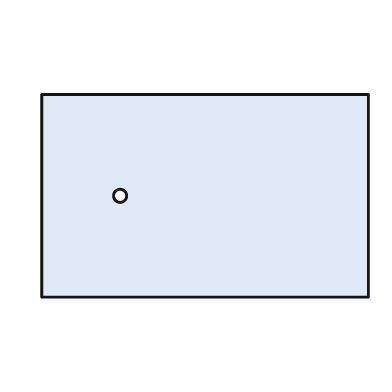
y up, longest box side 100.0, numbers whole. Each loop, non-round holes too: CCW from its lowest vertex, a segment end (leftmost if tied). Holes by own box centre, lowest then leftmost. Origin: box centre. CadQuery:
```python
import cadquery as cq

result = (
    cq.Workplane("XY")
    .moveTo(-50.0, -31.0)
    .lineTo(50.0, -31.0)
    .lineTo(50.0, 31.0)
    .lineTo(-50.0, 31.0)
    .close()
    .moveTo(-26.0, 0.0)
    .circle(2.0)
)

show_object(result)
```